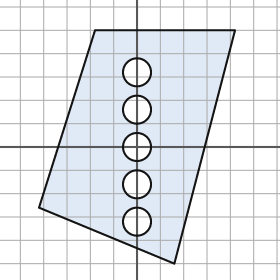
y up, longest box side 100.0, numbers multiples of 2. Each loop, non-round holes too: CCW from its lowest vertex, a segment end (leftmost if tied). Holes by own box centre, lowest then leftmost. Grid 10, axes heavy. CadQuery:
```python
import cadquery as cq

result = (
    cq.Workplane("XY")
    .moveTo(16.0, -50.0)
    .lineTo(42.0, 50.0)
    .lineTo(-18.0, 50.0)
    .lineTo(-42.0, -26.0)
    .close()
    .moveTo(0.0, -32.0)
    .circle(6.0)
    .moveTo(0.0, -16.0)
    .circle(6.0)
    .moveTo(0.0, 0.0)
    .circle(6.0)
    .moveTo(0.0, 16.0)
    .circle(6.0)
    .moveTo(0.0, 32.0)
    .circle(6.0)
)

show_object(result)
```